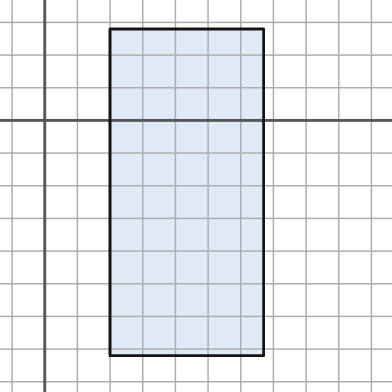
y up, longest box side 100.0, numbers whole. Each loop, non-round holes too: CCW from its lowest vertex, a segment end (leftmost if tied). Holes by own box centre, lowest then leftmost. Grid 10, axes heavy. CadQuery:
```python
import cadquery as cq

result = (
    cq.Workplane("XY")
    .moveTo(20.0, -72.0)
    .lineTo(67.0, -72.0)
    .lineTo(67.0, 28.0)
    .lineTo(20.0, 28.0)
    .close()
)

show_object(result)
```